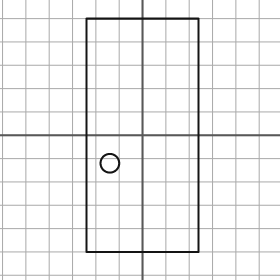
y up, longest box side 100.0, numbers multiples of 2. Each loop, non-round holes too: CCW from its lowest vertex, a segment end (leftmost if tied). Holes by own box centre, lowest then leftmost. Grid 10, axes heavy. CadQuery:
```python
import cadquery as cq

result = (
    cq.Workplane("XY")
    .moveTo(-24.0, -50.0)
    .lineTo(24.0, -50.0)
    .lineTo(24.0, 50.0)
    .lineTo(-24.0, 50.0)
    .close()
    .moveTo(-14.0, -12.0)
    .circle(4.0)
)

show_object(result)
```